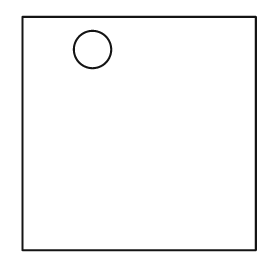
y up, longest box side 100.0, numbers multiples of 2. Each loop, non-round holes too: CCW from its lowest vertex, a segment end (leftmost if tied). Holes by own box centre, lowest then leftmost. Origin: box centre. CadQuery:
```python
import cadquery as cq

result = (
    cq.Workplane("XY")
    .moveTo(-50.0, -50.0)
    .lineTo(50.0, -50.0)
    .lineTo(50.0, 50.0)
    .lineTo(-50.0, 50.0)
    .close()
    .moveTo(-20.0, 36.0)
    .circle(8.0)
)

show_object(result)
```